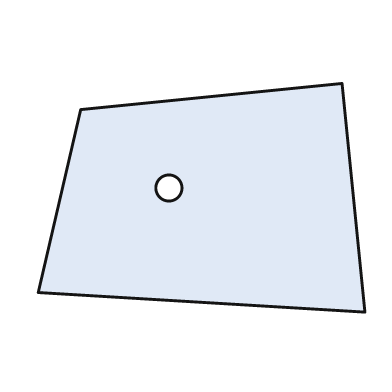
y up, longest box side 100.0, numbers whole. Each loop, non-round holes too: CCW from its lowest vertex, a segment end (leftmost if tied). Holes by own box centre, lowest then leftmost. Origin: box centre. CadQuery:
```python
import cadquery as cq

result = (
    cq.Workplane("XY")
    .moveTo(50.0, -35.0)
    .lineTo(43.0, 35.0)
    .lineTo(-37.0, 27.0)
    .lineTo(-50.0, -29.0)
    .close()
    .moveTo(-10.0, 3.0)
    .circle(4.0)
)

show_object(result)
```